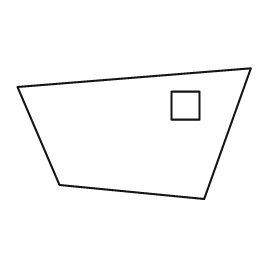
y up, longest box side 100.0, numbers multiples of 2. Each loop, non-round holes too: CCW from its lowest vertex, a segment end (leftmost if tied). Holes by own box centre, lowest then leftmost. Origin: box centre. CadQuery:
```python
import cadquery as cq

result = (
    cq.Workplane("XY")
    .moveTo(30.0, -28.0)
    .lineTo(50.0, 28.0)
    .lineTo(-50.0, 20.0)
    .lineTo(-32.0, -22.0)
    .close()
    .moveTo(16.0, 6.0)
    .lineTo(28.0, 6.0)
    .lineTo(28.0, 18.0)
    .lineTo(16.0, 18.0)
    .close()
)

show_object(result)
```